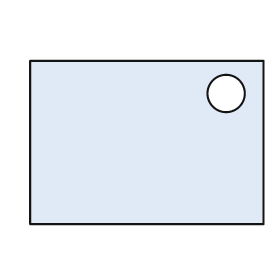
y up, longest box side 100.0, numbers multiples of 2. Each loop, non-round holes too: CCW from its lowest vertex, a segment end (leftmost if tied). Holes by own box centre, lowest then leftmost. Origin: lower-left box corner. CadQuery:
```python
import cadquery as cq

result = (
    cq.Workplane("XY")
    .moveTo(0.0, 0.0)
    .lineTo(100.0, 0.0)
    .lineTo(100.0, 70.0)
    .lineTo(0.0, 70.0)
    .close()
    .moveTo(84.0, 56.0)
    .circle(8.0)
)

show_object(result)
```